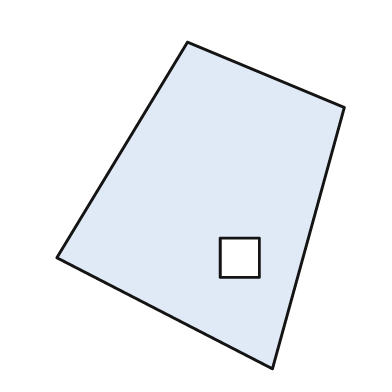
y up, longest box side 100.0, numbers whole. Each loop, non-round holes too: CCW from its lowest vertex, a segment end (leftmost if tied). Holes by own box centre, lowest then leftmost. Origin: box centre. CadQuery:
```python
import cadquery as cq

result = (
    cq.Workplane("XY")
    .moveTo(22.0, -50.0)
    .lineTo(44.0, 30.0)
    .lineTo(-4.0, 50.0)
    .lineTo(-44.0, -16.0)
    .close()
    .moveTo(6.0, -22.0)
    .lineTo(18.0, -22.0)
    .lineTo(18.0, -10.0)
    .lineTo(6.0, -10.0)
    .close()
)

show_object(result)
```